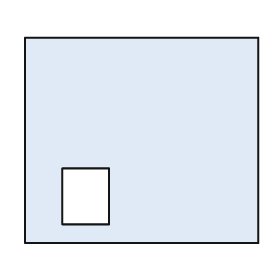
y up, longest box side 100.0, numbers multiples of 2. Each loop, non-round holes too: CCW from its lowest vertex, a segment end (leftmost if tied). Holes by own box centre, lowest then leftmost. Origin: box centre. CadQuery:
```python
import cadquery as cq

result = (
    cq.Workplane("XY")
    .moveTo(-50.0, -44.0)
    .lineTo(50.0, -44.0)
    .lineTo(50.0, 44.0)
    .lineTo(-50.0, 44.0)
    .close()
    .moveTo(-34.0, -36.0)
    .lineTo(-14.0, -36.0)
    .lineTo(-14.0, -12.0)
    .lineTo(-34.0, -12.0)
    .close()
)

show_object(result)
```